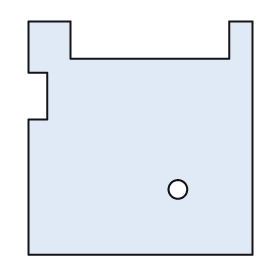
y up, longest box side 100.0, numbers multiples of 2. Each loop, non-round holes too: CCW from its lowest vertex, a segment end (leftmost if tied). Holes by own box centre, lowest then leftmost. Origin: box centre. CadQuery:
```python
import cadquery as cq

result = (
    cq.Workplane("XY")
    .moveTo(-48.0, -50.0)
    .lineTo(48.0, -50.0)
    .lineTo(48.0, 50.0)
    .lineTo(38.0, 50.0)
    .lineTo(38.0, 34.0)
    .lineTo(-30.0, 34.0)
    .lineTo(-30.0, 50.0)
    .lineTo(-48.0, 50.0)
    .lineTo(-48.0, 28.0)
    .lineTo(-40.0, 28.0)
    .lineTo(-40.0, 8.0)
    .lineTo(-48.0, 8.0)
    .close()
    .moveTo(16.0, -22.0)
    .circle(4.0)
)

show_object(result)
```